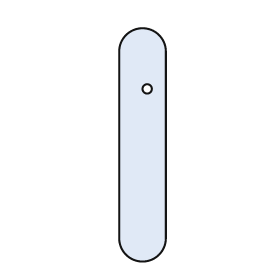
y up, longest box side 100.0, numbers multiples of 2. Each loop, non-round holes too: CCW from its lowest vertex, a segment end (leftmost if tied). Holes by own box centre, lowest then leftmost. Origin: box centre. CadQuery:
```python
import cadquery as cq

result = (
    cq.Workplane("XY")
    .moveTo(-10.0, -40.0)
    .threePointArc((0.0, -50.0), (10.0, -40.0))
    .lineTo(10.0, 40.0)
    .threePointArc((0.0, 50.0), (-10.0, 40.0))
    .close()
    .moveTo(2.0, 24.0)
    .circle(2.0)
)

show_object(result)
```